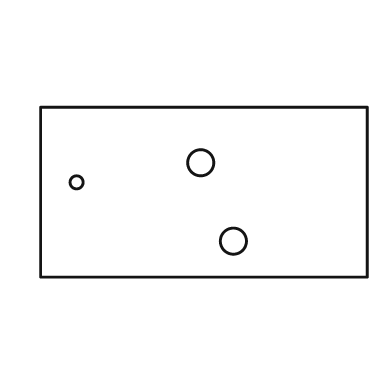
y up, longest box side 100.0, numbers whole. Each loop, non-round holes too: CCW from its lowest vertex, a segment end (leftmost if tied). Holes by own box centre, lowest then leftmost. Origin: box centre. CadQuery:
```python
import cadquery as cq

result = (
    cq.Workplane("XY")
    .moveTo(-50.0, -26.0)
    .lineTo(50.0, -26.0)
    .lineTo(50.0, 26.0)
    .lineTo(-50.0, 26.0)
    .close()
    .moveTo(9.0, -15.0)
    .circle(4.0)
    .moveTo(-39.0, 3.0)
    .circle(2.0)
    .moveTo(-1.0, 9.0)
    .circle(4.0)
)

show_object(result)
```